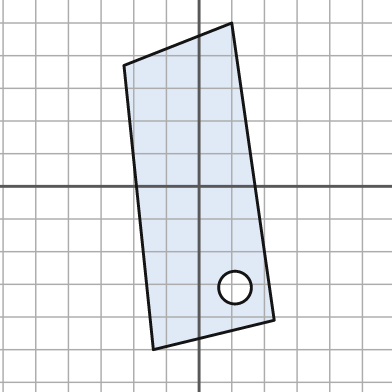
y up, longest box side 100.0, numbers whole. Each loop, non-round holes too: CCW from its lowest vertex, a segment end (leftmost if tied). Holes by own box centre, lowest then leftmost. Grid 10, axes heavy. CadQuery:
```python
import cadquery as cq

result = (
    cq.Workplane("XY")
    .moveTo(-14.0, -50.0)
    .lineTo(23.0, -41.0)
    .lineTo(10.0, 50.0)
    .lineTo(-23.0, 37.0)
    .close()
    .moveTo(11.0, -31.0)
    .circle(5.0)
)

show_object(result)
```